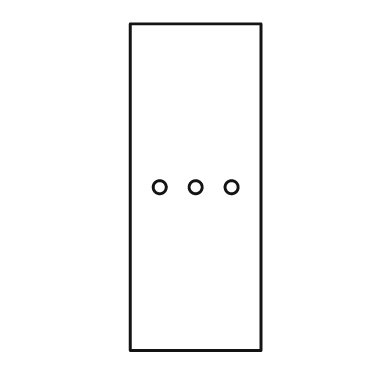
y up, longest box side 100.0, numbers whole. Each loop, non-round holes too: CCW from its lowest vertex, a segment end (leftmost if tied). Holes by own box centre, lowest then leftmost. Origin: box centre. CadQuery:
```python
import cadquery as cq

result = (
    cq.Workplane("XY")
    .moveTo(-20.0, -50.0)
    .lineTo(20.0, -50.0)
    .lineTo(20.0, 50.0)
    .lineTo(-20.0, 50.0)
    .close()
    .moveTo(-11.0, 0.0)
    .circle(2.0)
    .moveTo(0.0, 0.0)
    .circle(2.0)
    .moveTo(11.0, 0.0)
    .circle(2.0)
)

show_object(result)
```